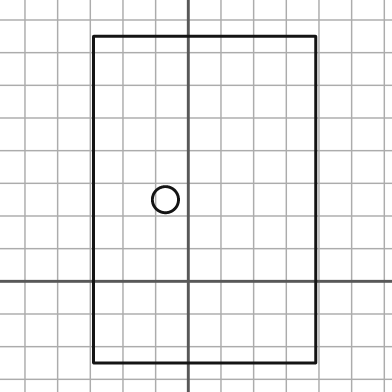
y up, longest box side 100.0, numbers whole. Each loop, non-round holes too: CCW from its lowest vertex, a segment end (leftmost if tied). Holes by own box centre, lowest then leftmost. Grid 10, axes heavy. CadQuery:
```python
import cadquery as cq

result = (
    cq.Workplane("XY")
    .moveTo(-29.0, -25.0)
    .lineTo(39.0, -25.0)
    .lineTo(39.0, 75.0)
    .lineTo(-29.0, 75.0)
    .close()
    .moveTo(-7.0, 25.0)
    .circle(4.0)
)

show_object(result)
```